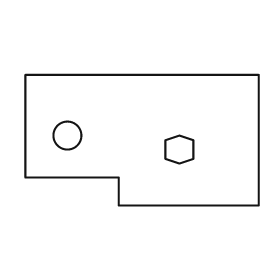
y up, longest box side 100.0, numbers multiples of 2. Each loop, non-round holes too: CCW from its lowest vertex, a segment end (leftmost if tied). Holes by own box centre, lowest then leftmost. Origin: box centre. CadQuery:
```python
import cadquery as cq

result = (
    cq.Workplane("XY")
    .moveTo(-10.0, -28.0)
    .lineTo(50.0, -28.0)
    .lineTo(50.0, 28.0)
    .lineTo(-50.0, 28.0)
    .lineTo(-50.0, -16.0)
    .lineTo(-10.0, -16.0)
    .close()
    .moveTo(16.0, -10.0)
    .lineTo(22.0, -8.0)
    .lineTo(22.0, 0.0)
    .lineTo(16.0, 2.0)
    .lineTo(10.0, 0.0)
    .lineTo(10.0, -8.0)
    .close()
    .moveTo(-32.0, 2.0)
    .circle(6.0)
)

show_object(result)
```